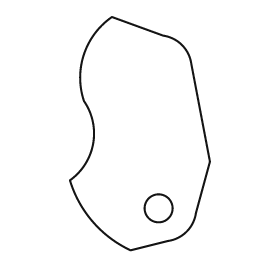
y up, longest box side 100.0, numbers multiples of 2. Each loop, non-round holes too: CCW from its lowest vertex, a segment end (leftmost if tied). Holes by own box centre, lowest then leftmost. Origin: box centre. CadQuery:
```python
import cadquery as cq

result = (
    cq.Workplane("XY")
    .moveTo(-4.0, -50.0)
    .lineTo(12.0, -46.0)
    .threePointArc((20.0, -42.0), (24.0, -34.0))
    .lineTo(30.0, -12.0)
    .lineTo(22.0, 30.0)
    .threePointArc((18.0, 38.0), (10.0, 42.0))
    .lineTo(-12.0, 50.0)
    .threePointArc((-24.0, 34.0), (-24.0, 14.0))
    .threePointArc((-20.0, -4.0), (-30.0, -20.0))
    .threePointArc((-20.0, -38.0), (-4.0, -50.0))
    .close()
    .moveTo(8.0, -32.0)
    .circle(6.0)
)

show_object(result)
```